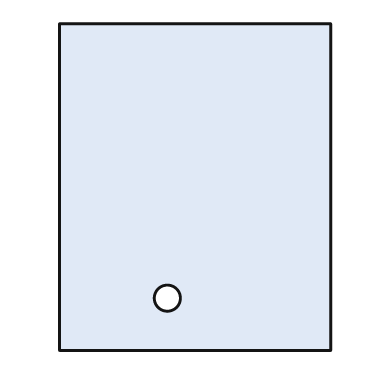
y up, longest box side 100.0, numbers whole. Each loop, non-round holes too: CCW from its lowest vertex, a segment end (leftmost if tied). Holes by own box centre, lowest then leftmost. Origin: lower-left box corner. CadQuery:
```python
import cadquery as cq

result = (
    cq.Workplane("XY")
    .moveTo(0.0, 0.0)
    .lineTo(83.0, 0.0)
    .lineTo(83.0, 100.0)
    .lineTo(0.0, 100.0)
    .close()
    .moveTo(33.0, 16.0)
    .circle(4.0)
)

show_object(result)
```